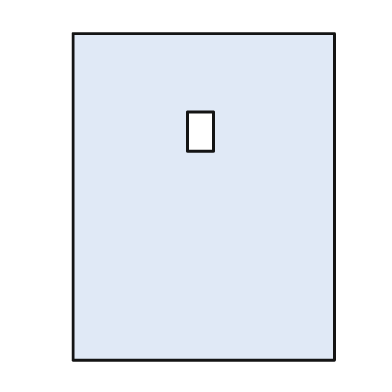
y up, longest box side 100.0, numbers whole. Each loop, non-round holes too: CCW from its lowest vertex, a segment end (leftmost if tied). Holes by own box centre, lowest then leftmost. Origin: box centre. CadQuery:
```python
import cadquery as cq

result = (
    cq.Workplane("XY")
    .moveTo(-40.0, -50.0)
    .lineTo(40.0, -50.0)
    .lineTo(40.0, 50.0)
    .lineTo(-40.0, 50.0)
    .close()
    .moveTo(-5.0, 14.0)
    .lineTo(3.0, 14.0)
    .lineTo(3.0, 26.0)
    .lineTo(-5.0, 26.0)
    .close()
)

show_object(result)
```